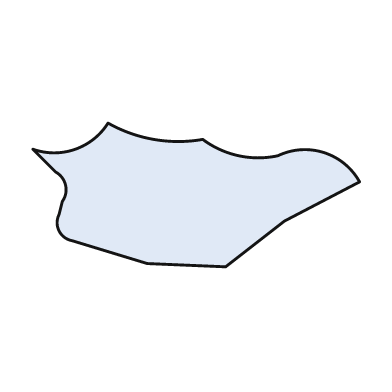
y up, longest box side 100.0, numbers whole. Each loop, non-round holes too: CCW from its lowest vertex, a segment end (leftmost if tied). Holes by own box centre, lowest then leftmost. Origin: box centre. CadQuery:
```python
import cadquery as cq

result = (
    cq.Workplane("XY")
    .moveTo(9.0, -22.0)
    .lineTo(27.0, -8.0)
    .lineTo(50.0, 4.0)
    .threePointArc((39.0, 13.0), (25.0, 12.0))
    .threePointArc((13.0, 12.0), (2.0, 17.0))
    .threePointArc((-13.0, 17.0), (-27.0, 22.0))
    .threePointArc((-37.0, 14.0), (-50.0, 14.0))
    .lineTo(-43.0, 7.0)
    .threePointArc((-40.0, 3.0), (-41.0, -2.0))
    .lineTo(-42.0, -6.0)
    .threePointArc((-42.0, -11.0), (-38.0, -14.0))
    .lineTo(-15.0, -21.0)
    .close()
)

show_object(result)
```